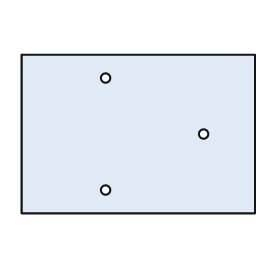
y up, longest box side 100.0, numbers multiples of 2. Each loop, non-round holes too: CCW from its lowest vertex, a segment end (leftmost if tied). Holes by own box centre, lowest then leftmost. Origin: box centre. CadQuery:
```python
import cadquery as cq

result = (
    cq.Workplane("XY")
    .moveTo(-50.0, -34.0)
    .lineTo(50.0, -34.0)
    .lineTo(50.0, 34.0)
    .lineTo(-50.0, 34.0)
    .close()
    .moveTo(-14.0, -24.0)
    .circle(2.0)
    .moveTo(28.0, 0.0)
    .circle(2.0)
    .moveTo(-14.0, 24.0)
    .circle(2.0)
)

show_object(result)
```